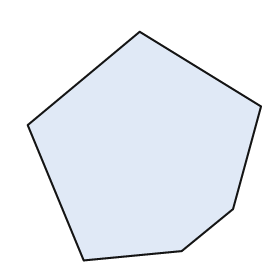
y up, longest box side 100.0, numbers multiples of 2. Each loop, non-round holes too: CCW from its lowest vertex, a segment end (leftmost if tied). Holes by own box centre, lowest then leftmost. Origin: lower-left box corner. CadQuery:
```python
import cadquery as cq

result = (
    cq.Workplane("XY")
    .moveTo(24.0, 0.0)
    .lineTo(66.0, 4.0)
    .lineTo(88.0, 22.0)
    .lineTo(100.0, 66.0)
    .lineTo(48.0, 98.0)
    .lineTo(0.0, 58.0)
    .close()
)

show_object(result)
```